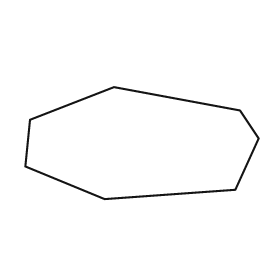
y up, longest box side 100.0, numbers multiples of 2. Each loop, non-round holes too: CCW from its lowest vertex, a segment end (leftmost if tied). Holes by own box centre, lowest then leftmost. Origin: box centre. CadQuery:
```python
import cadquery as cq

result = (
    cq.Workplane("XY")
    .moveTo(-16.0, -24.0)
    .lineTo(40.0, -20.0)
    .lineTo(50.0, 2.0)
    .lineTo(42.0, 14.0)
    .lineTo(-12.0, 24.0)
    .lineTo(-48.0, 10.0)
    .lineTo(-50.0, -10.0)
    .close()
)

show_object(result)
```